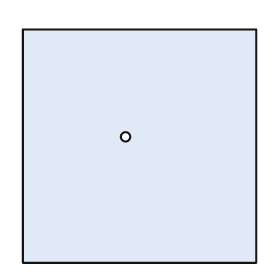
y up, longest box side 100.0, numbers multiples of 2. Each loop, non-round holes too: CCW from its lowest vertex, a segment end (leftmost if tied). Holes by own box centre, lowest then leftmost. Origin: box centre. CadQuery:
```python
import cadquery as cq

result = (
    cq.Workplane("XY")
    .moveTo(-50.0, -50.0)
    .lineTo(50.0, -50.0)
    .lineTo(50.0, 50.0)
    .lineTo(-50.0, 50.0)
    .close()
    .moveTo(-6.0, 4.0)
    .circle(2.0)
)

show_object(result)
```